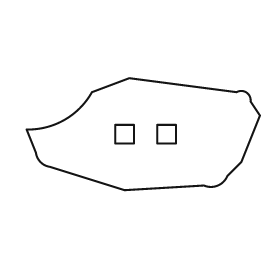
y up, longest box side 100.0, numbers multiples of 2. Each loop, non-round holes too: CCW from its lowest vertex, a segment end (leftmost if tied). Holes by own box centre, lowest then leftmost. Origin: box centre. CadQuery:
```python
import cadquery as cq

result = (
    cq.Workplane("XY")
    .moveTo(-8.0, -24.0)
    .lineTo(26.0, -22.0)
    .threePointArc((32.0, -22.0), (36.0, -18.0))
    .lineTo(42.0, -12.0)
    .lineTo(50.0, 8.0)
    .lineTo(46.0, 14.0)
    .threePointArc((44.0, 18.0), (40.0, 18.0))
    .lineTo(-6.0, 24.0)
    .lineTo(-22.0, 18.0)
    .threePointArc((-34.0, 6.0), (-50.0, 2.0))
    .lineTo(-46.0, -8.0)
    .threePointArc((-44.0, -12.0), (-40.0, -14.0))
    .close()
    .moveTo(-12.0, -4.0)
    .lineTo(-4.0, -4.0)
    .lineTo(-4.0, 4.0)
    .lineTo(-12.0, 4.0)
    .close()
    .moveTo(6.0, -4.0)
    .lineTo(14.0, -4.0)
    .lineTo(14.0, 4.0)
    .lineTo(6.0, 4.0)
    .close()
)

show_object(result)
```